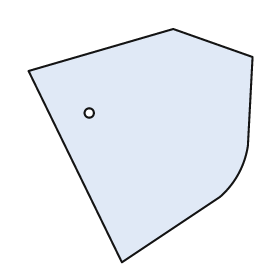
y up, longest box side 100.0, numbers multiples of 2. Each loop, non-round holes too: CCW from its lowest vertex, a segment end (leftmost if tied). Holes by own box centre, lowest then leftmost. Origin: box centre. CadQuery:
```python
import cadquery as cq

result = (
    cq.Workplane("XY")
    .moveTo(-8.0, -50.0)
    .lineTo(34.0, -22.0)
    .threePointArc((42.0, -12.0), (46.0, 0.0))
    .lineTo(48.0, 38.0)
    .lineTo(14.0, 50.0)
    .lineTo(-48.0, 32.0)
    .close()
    .moveTo(-22.0, 14.0)
    .circle(2.0)
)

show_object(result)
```